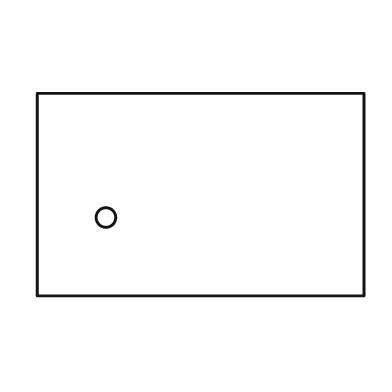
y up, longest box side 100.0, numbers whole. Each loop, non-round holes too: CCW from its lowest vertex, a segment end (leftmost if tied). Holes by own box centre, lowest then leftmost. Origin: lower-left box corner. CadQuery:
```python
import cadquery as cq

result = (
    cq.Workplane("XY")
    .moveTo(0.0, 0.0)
    .lineTo(100.0, 0.0)
    .lineTo(100.0, 62.0)
    .lineTo(0.0, 62.0)
    .close()
    .moveTo(21.0, 24.0)
    .circle(3.0)
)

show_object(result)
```